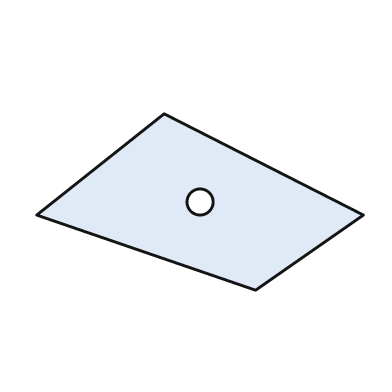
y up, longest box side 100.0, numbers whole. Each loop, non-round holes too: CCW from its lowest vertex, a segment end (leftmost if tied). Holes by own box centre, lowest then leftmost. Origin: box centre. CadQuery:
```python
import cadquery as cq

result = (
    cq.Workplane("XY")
    .moveTo(17.0, -27.0)
    .lineTo(50.0, -4.0)
    .lineTo(-11.0, 27.0)
    .lineTo(-50.0, -4.0)
    .close()
    .moveTo(0.0, 0.0)
    .circle(4.0)
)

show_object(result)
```